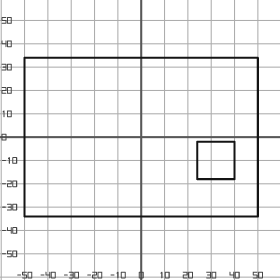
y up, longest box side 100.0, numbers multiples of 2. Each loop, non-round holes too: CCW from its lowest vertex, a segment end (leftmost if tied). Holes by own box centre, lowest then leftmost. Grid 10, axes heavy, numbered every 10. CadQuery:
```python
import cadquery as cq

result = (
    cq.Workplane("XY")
    .moveTo(-50.0, -34.0)
    .lineTo(50.0, -34.0)
    .lineTo(50.0, 34.0)
    .lineTo(-50.0, 34.0)
    .close()
    .moveTo(24.0, -18.0)
    .lineTo(40.0, -18.0)
    .lineTo(40.0, -2.0)
    .lineTo(24.0, -2.0)
    .close()
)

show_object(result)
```